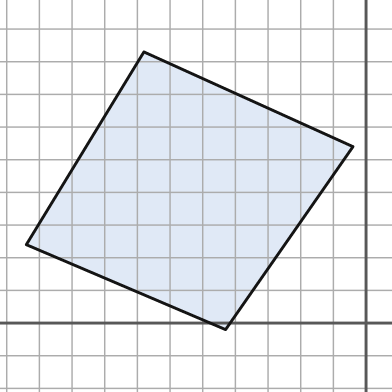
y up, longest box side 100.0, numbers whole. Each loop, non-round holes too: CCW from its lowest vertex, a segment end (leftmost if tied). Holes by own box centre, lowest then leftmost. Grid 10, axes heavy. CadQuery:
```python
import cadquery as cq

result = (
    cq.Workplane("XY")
    .moveTo(-43.0, -2.0)
    .lineTo(-4.0, 54.0)
    .lineTo(-68.0, 83.0)
    .lineTo(-104.0, 24.0)
    .close()
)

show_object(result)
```